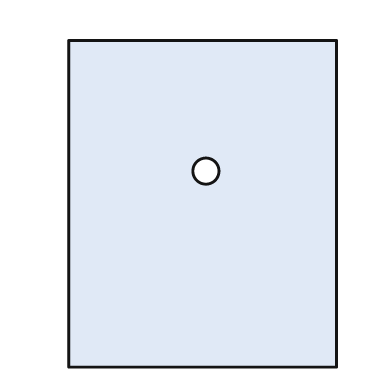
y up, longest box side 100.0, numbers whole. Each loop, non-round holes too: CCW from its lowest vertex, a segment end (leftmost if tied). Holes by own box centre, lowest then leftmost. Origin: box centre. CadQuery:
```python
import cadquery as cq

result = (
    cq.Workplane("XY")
    .moveTo(-41.0, -50.0)
    .lineTo(41.0, -50.0)
    .lineTo(41.0, 50.0)
    .lineTo(-41.0, 50.0)
    .close()
    .moveTo(1.0, 10.0)
    .circle(4.0)
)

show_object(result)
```